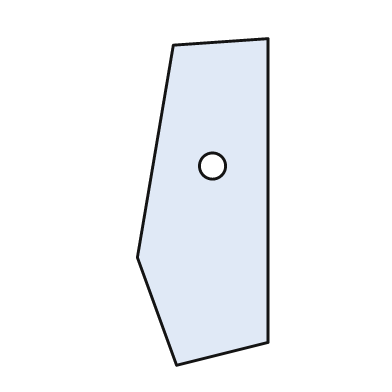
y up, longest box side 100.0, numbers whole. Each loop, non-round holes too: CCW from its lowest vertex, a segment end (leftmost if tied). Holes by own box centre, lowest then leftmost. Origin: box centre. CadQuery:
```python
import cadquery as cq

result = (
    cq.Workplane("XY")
    .moveTo(-8.0, -50.0)
    .lineTo(20.0, -43.0)
    .lineTo(20.0, 50.0)
    .lineTo(-9.0, 48.0)
    .lineTo(-20.0, -17.0)
    .close()
    .moveTo(3.0, 11.0)
    .circle(4.0)
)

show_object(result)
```